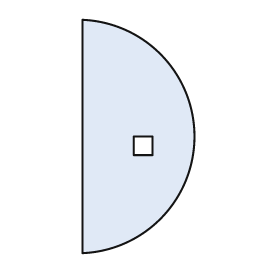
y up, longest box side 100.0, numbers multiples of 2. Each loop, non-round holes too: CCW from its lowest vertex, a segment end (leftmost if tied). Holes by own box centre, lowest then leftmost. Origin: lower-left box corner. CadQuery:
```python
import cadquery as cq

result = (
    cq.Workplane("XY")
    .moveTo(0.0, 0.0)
    .threePointArc((48.0, 50.0), (0.0, 100.0))
    .close()
    .moveTo(22.0, 42.0)
    .lineTo(30.0, 42.0)
    .lineTo(30.0, 50.0)
    .lineTo(22.0, 50.0)
    .close()
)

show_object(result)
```